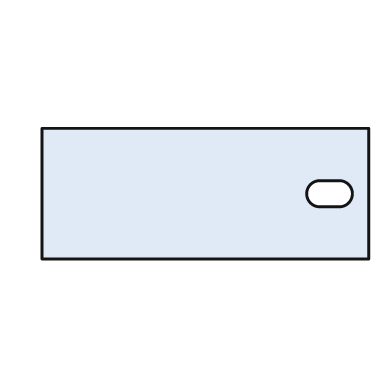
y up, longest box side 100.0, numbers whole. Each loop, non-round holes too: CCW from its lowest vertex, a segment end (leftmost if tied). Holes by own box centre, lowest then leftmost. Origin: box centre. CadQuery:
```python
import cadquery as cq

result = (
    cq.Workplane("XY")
    .moveTo(-50.0, -20.0)
    .lineTo(50.0, -20.0)
    .lineTo(50.0, 20.0)
    .lineTo(-50.0, 20.0)
    .close()
    .moveTo(35.0, -4.0)
    .lineTo(41.0, -4.0)
    .threePointArc((45.0, 0.0), (41.0, 4.0))
    .lineTo(35.0, 4.0)
    .threePointArc((31.0, 0.0), (35.0, -4.0))
    .close()
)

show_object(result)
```